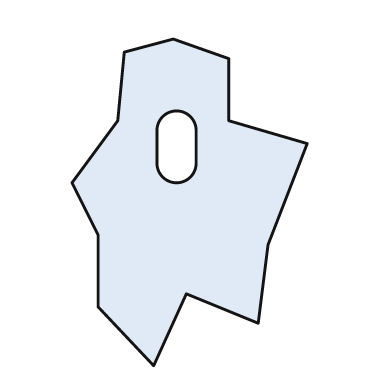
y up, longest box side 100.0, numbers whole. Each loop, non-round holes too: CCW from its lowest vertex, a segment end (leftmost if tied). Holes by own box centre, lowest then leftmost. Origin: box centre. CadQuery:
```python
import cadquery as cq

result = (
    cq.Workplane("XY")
    .moveTo(-11.0, -50.0)
    .lineTo(-1.0, -28.0)
    .lineTo(21.0, -37.0)
    .lineTo(24.0, -13.0)
    .lineTo(36.0, 18.0)
    .lineTo(12.0, 25.0)
    .lineTo(12.0, 44.0)
    .lineTo(-5.0, 50.0)
    .lineTo(-20.0, 46.0)
    .lineTo(-22.0, 25.0)
    .lineTo(-36.0, 6.0)
    .lineTo(-28.0, -10.0)
    .lineTo(-28.0, -32.0)
    .close()
    .moveTo(-10.0, 12.0)
    .threePointArc((-4.0, 6.0), (2.0, 12.0))
    .lineTo(2.0, 22.0)
    .threePointArc((-4.0, 28.0), (-10.0, 22.0))
    .close()
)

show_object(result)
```